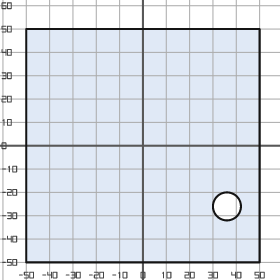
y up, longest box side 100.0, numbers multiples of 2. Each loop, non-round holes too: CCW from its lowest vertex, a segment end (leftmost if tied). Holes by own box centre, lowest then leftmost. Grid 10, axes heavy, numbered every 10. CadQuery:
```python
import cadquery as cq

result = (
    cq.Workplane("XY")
    .moveTo(-50.0, -50.0)
    .lineTo(50.0, -50.0)
    .lineTo(50.0, 50.0)
    .lineTo(-50.0, 50.0)
    .close()
    .moveTo(36.0, -26.0)
    .circle(6.0)
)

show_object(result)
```